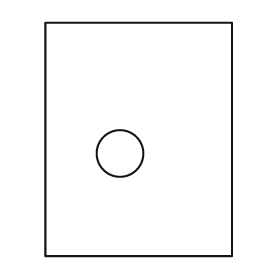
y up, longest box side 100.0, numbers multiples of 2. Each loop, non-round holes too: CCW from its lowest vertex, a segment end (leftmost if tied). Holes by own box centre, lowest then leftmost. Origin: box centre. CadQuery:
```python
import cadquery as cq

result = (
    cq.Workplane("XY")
    .moveTo(-40.0, -50.0)
    .lineTo(40.0, -50.0)
    .lineTo(40.0, 50.0)
    .lineTo(-40.0, 50.0)
    .close()
    .moveTo(-8.0, -6.0)
    .circle(10.0)
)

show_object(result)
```